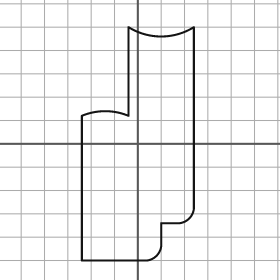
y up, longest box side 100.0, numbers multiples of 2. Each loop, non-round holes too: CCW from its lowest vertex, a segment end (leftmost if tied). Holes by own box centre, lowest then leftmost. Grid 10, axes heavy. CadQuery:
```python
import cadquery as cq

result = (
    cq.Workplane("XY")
    .moveTo(-24.0, -50.0)
    .lineTo(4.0, -50.0)
    .threePointArc((8.0, -48.0), (10.0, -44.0))
    .lineTo(10.0, -34.0)
    .lineTo(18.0, -34.0)
    .threePointArc((22.0, -32.0), (24.0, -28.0))
    .lineTo(24.0, 50.0)
    .threePointArc((10.0, 46.0), (-4.0, 50.0))
    .lineTo(-4.0, 12.0)
    .threePointArc((-14.0, 14.0), (-24.0, 12.0))
    .close()
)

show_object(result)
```